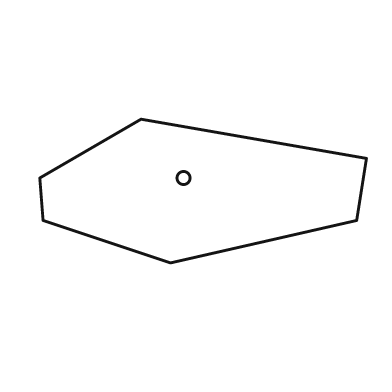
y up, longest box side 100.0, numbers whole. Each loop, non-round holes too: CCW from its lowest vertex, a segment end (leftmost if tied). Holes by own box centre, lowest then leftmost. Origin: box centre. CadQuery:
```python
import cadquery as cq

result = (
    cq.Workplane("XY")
    .moveTo(-10.0, -22.0)
    .lineTo(47.0, -9.0)
    .lineTo(50.0, 10.0)
    .lineTo(-19.0, 22.0)
    .lineTo(-50.0, 4.0)
    .lineTo(-49.0, -9.0)
    .close()
    .moveTo(-6.0, 4.0)
    .circle(2.0)
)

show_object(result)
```